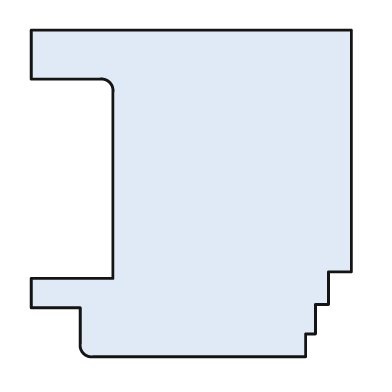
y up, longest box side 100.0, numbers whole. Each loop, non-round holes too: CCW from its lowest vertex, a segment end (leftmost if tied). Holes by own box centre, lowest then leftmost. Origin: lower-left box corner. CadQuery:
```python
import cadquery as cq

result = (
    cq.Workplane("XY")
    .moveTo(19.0, 0.0)
    .lineTo(84.0, 0.0)
    .lineTo(84.0, 7.0)
    .lineTo(87.0, 7.0)
    .lineTo(87.0, 16.0)
    .lineTo(91.0, 16.0)
    .lineTo(91.0, 26.0)
    .lineTo(98.0, 26.0)
    .lineTo(98.0, 100.0)
    .lineTo(0.0, 100.0)
    .lineTo(0.0, 85.0)
    .lineTo(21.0, 85.0)
    .threePointArc((24.0, 84.0), (25.0, 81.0))
    .lineTo(25.0, 24.0)
    .lineTo(0.0, 24.0)
    .lineTo(0.0, 15.0)
    .lineTo(15.0, 15.0)
    .lineTo(15.0, 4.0)
    .threePointArc((16.0, 1.0), (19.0, 0.0))
    .close()
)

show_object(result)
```